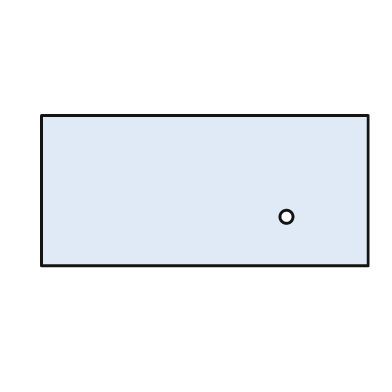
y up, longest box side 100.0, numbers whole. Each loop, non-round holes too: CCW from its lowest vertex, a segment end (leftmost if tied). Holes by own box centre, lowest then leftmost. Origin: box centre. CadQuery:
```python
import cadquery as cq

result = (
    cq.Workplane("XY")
    .moveTo(-50.0, -23.0)
    .lineTo(50.0, -23.0)
    .lineTo(50.0, 23.0)
    .lineTo(-50.0, 23.0)
    .close()
    .moveTo(25.0, -8.0)
    .circle(2.0)
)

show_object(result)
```